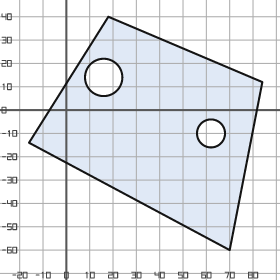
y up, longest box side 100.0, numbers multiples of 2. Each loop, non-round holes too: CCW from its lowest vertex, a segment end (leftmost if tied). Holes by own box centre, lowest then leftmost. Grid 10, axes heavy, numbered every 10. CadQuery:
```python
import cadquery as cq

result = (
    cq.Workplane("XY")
    .moveTo(70.0, -60.0)
    .lineTo(84.0, 12.0)
    .lineTo(18.0, 40.0)
    .lineTo(-16.0, -14.0)
    .close()
    .moveTo(62.0, -10.0)
    .circle(6.0)
    .moveTo(16.0, 14.0)
    .circle(8.0)
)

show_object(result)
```